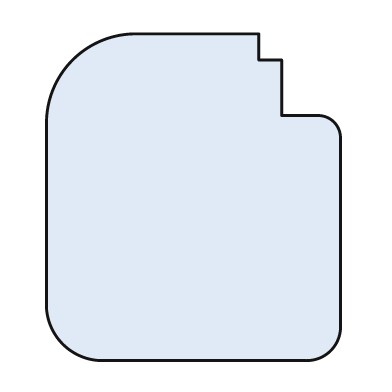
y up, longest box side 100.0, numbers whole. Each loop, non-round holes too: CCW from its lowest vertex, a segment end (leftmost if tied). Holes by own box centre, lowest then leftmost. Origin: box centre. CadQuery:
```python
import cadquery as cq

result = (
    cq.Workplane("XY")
    .moveTo(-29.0, -50.0)
    .lineTo(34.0, -50.0)
    .threePointArc((42.0, -47.0), (45.0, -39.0))
    .lineTo(45.0, 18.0)
    .threePointArc((43.0, 23.0), (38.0, 25.0))
    .lineTo(27.0, 25.0)
    .lineTo(27.0, 42.0)
    .lineTo(20.0, 42.0)
    .lineTo(20.0, 50.0)
    .lineTo(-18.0, 50.0)
    .threePointArc((-37.0, 42.0), (-45.0, 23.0))
    .lineTo(-45.0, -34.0)
    .threePointArc((-40.0, -45.0), (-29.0, -50.0))
    .close()
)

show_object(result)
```